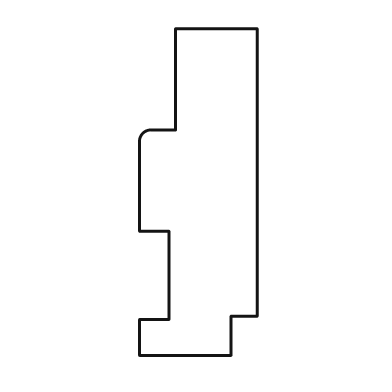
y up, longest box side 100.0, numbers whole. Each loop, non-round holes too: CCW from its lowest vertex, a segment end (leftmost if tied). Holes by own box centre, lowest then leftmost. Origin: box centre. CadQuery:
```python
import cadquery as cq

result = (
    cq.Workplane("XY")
    .moveTo(-18.0, -50.0)
    .lineTo(10.0, -50.0)
    .lineTo(10.0, -38.0)
    .lineTo(18.0, -38.0)
    .lineTo(18.0, 50.0)
    .lineTo(-7.0, 50.0)
    .lineTo(-7.0, 19.0)
    .lineTo(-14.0, 19.0)
    .threePointArc((-17.0, 18.0), (-18.0, 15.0))
    .lineTo(-18.0, -12.0)
    .lineTo(-9.0, -12.0)
    .lineTo(-9.0, -39.0)
    .lineTo(-18.0, -39.0)
    .close()
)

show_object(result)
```